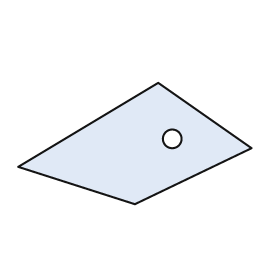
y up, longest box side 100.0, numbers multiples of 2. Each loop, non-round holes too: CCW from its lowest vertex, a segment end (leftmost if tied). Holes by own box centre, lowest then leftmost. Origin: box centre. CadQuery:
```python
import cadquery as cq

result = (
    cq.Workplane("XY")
    .moveTo(0.0, -26.0)
    .lineTo(50.0, -2.0)
    .lineTo(10.0, 26.0)
    .lineTo(-50.0, -10.0)
    .close()
    .moveTo(16.0, 2.0)
    .circle(4.0)
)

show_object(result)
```